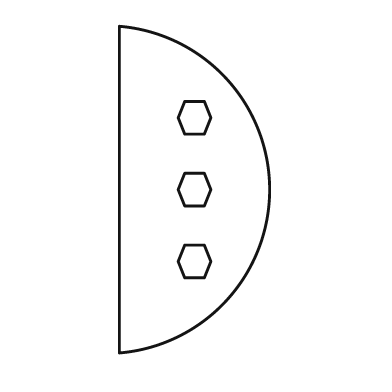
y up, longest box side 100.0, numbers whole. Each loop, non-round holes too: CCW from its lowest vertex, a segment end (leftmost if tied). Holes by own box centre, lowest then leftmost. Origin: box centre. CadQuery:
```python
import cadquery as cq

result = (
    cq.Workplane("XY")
    .moveTo(-23.0, -50.0)
    .threePointArc((23.0, 0.0), (-23.0, 50.0))
    .close()
    .moveTo(-3.0, -27.0)
    .lineTo(3.0, -27.0)
    .lineTo(5.0, -22.0)
    .lineTo(3.0, -17.0)
    .lineTo(-3.0, -17.0)
    .lineTo(-5.0, -22.0)
    .close()
    .moveTo(-3.0, -5.0)
    .lineTo(3.0, -5.0)
    .lineTo(5.0, 0.0)
    .lineTo(3.0, 5.0)
    .lineTo(-3.0, 5.0)
    .lineTo(-5.0, 0.0)
    .close()
    .moveTo(-3.0, 17.0)
    .lineTo(3.0, 17.0)
    .lineTo(5.0, 22.0)
    .lineTo(3.0, 27.0)
    .lineTo(-3.0, 27.0)
    .lineTo(-5.0, 22.0)
    .close()
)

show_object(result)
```